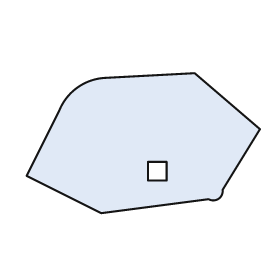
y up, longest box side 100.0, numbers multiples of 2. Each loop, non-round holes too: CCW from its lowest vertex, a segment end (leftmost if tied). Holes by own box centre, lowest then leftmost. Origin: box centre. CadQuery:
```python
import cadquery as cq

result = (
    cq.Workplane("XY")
    .moveTo(-18.0, -30.0)
    .lineTo(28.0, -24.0)
    .threePointArc((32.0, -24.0), (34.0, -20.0))
    .lineTo(50.0, 6.0)
    .lineTo(22.0, 30.0)
    .lineTo(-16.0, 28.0)
    .threePointArc((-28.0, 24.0), (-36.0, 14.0))
    .lineTo(-50.0, -14.0)
    .close()
    .moveTo(2.0, -16.0)
    .lineTo(10.0, -16.0)
    .lineTo(10.0, -8.0)
    .lineTo(2.0, -8.0)
    .close()
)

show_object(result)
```